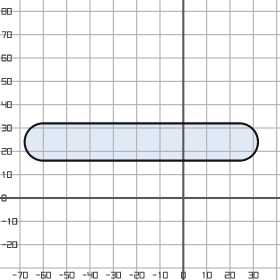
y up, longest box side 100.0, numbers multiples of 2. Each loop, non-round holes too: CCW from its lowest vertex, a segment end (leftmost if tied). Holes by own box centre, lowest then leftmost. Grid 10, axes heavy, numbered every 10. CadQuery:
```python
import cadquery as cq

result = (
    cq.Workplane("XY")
    .moveTo(-60.0, 16.0)
    .lineTo(24.0, 16.0)
    .threePointArc((32.0, 24.0), (24.0, 32.0))
    .lineTo(-60.0, 32.0)
    .threePointArc((-68.0, 24.0), (-60.0, 16.0))
    .close()
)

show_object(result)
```